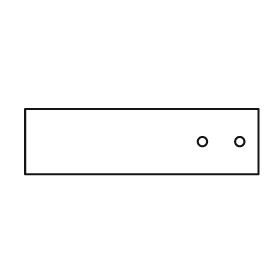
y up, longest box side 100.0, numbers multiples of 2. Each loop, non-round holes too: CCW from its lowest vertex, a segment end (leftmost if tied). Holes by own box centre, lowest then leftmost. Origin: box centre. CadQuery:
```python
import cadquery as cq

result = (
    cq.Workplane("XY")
    .moveTo(-50.0, -14.0)
    .lineTo(50.0, -14.0)
    .lineTo(50.0, 14.0)
    .lineTo(-50.0, 14.0)
    .close()
    .moveTo(26.0, 0.0)
    .circle(2.0)
    .moveTo(42.0, 0.0)
    .circle(2.0)
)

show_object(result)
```